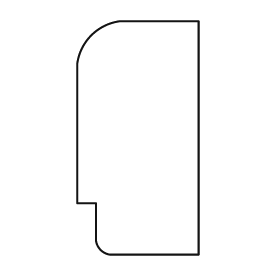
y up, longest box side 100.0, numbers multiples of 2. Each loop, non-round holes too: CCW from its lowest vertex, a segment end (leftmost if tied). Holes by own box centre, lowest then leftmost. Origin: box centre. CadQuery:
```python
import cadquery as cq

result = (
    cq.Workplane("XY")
    .moveTo(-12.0, -50.0)
    .lineTo(26.0, -50.0)
    .lineTo(26.0, 50.0)
    .lineTo(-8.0, 50.0)
    .threePointArc((-20.0, 44.0), (-26.0, 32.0))
    .lineTo(-26.0, -28.0)
    .lineTo(-18.0, -28.0)
    .lineTo(-18.0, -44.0)
    .threePointArc((-16.0, -48.0), (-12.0, -50.0))
    .close()
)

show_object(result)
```